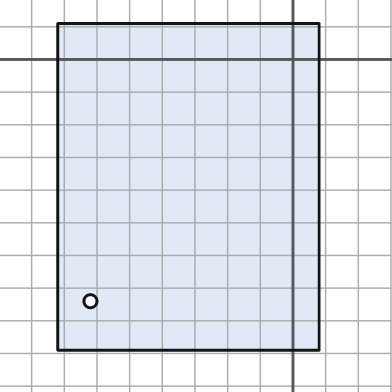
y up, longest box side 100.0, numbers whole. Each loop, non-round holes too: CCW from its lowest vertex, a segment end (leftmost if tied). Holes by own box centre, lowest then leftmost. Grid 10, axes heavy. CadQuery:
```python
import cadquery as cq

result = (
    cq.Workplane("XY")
    .moveTo(-72.0, -89.0)
    .lineTo(8.0, -89.0)
    .lineTo(8.0, 11.0)
    .lineTo(-72.0, 11.0)
    .close()
    .moveTo(-62.0, -74.0)
    .circle(2.0)
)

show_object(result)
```